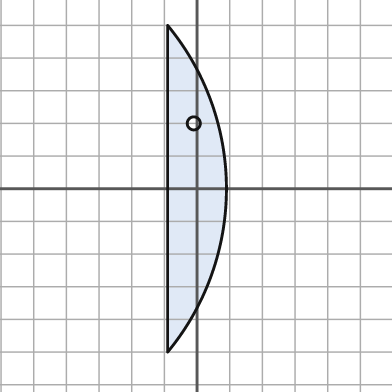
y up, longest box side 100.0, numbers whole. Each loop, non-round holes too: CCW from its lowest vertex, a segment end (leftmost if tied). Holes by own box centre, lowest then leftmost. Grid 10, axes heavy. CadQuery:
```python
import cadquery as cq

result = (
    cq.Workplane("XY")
    .moveTo(-9.0, -50.0)
    .threePointArc((9.0, 0.0), (-9.0, 50.0))
    .close()
    .moveTo(-1.0, 20.0)
    .circle(2.0)
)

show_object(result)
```